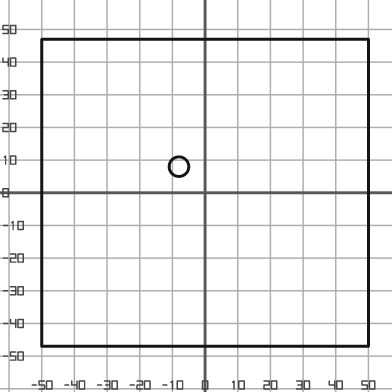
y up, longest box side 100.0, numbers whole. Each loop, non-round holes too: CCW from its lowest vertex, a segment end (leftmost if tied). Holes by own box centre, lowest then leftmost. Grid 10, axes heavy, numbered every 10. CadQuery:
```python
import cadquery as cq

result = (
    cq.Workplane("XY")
    .moveTo(-50.0, -47.0)
    .lineTo(50.0, -47.0)
    .lineTo(50.0, 47.0)
    .lineTo(-50.0, 47.0)
    .close()
    .moveTo(-8.0, 8.0)
    .circle(3.0)
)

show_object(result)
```